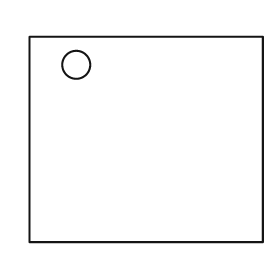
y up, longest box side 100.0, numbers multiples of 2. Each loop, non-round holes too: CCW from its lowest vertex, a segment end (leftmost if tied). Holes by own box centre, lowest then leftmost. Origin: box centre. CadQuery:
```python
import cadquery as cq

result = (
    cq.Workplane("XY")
    .moveTo(-50.0, -44.0)
    .lineTo(50.0, -44.0)
    .lineTo(50.0, 44.0)
    .lineTo(-50.0, 44.0)
    .close()
    .moveTo(-30.0, 32.0)
    .circle(6.0)
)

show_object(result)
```